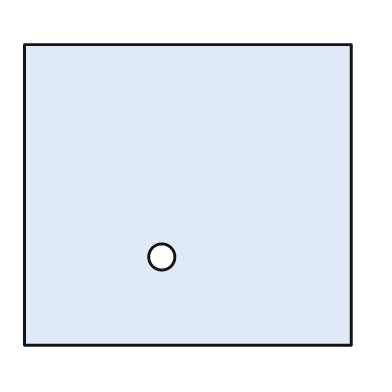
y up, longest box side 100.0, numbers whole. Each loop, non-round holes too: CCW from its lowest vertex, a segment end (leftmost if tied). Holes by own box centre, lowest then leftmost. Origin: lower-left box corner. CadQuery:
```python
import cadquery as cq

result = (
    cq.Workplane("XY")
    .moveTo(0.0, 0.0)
    .lineTo(100.0, 0.0)
    .lineTo(100.0, 92.0)
    .lineTo(0.0, 92.0)
    .close()
    .moveTo(42.0, 27.0)
    .circle(4.0)
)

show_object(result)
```